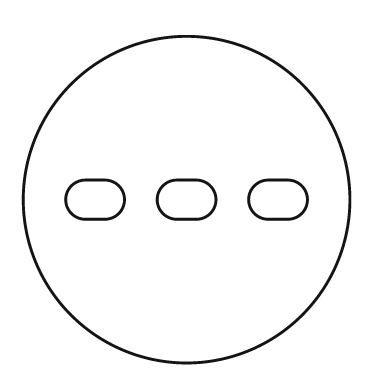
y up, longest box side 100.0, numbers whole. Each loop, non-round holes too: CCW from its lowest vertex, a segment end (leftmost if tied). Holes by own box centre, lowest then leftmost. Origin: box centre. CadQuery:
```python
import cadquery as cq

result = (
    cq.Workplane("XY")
    .moveTo(0.0, 0.0)
    .circle(50.0)
    .moveTo(-31.0, -6.0)
    .lineTo(-25.0, -6.0)
    .threePointArc((-19.0, 0.0), (-25.0, 6.0))
    .lineTo(-31.0, 6.0)
    .threePointArc((-37.0, 0.0), (-31.0, -6.0))
    .close()
    .moveTo(-3.0, -6.0)
    .lineTo(3.0, -6.0)
    .threePointArc((9.0, 0.0), (3.0, 6.0))
    .lineTo(-3.0, 6.0)
    .threePointArc((-9.0, 0.0), (-3.0, -6.0))
    .close()
    .moveTo(25.0, -6.0)
    .lineTo(31.0, -6.0)
    .threePointArc((37.0, 0.0), (31.0, 6.0))
    .lineTo(25.0, 6.0)
    .threePointArc((19.0, 0.0), (25.0, -6.0))
    .close()
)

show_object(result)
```